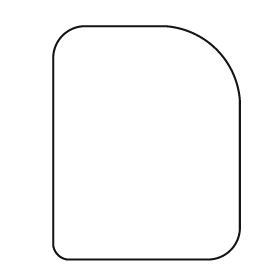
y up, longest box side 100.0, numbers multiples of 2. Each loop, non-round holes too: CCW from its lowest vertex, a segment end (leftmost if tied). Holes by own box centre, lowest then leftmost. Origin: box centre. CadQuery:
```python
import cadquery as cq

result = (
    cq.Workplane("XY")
    .moveTo(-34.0, -50.0)
    .lineTo(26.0, -50.0)
    .threePointArc((36.0, -46.0), (40.0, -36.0))
    .lineTo(40.0, 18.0)
    .threePointArc((30.0, 40.0), (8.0, 50.0))
    .lineTo(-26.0, 50.0)
    .threePointArc((-36.0, 46.0), (-40.0, 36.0))
    .lineTo(-40.0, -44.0)
    .threePointArc((-38.0, -48.0), (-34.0, -50.0))
    .close()
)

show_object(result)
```